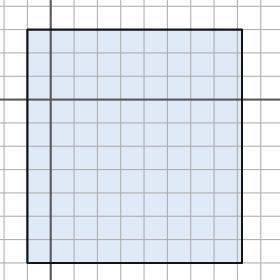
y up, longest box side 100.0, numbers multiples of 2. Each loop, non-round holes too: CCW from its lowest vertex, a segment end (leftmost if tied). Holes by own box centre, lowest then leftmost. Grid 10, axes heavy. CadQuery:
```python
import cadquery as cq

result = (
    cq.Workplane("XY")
    .moveTo(-10.0, -70.0)
    .lineTo(82.0, -70.0)
    .lineTo(82.0, 30.0)
    .lineTo(-10.0, 30.0)
    .close()
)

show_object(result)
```